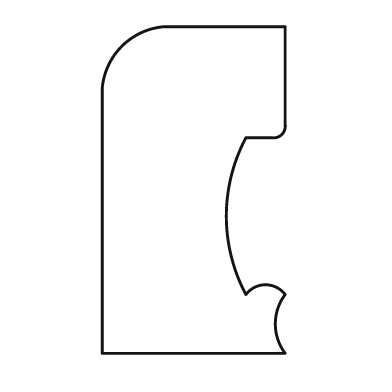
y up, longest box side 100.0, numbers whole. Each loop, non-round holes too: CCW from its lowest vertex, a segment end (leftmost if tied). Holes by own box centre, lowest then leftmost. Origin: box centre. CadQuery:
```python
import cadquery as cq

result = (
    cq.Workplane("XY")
    .moveTo(-28.0, -50.0)
    .lineTo(28.0, -50.0)
    .threePointArc((25.0, -41.0), (28.0, -32.0))
    .threePointArc((22.0, -29.0), (16.0, -32.0))
    .threePointArc((10.0, -8.0), (16.0, 16.0))
    .lineTo(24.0, 16.0)
    .threePointArc((27.0, 17.0), (28.0, 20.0))
    .lineTo(28.0, 50.0)
    .lineTo(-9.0, 50.0)
    .threePointArc((-22.0, 44.0), (-28.0, 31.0))
    .close()
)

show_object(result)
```